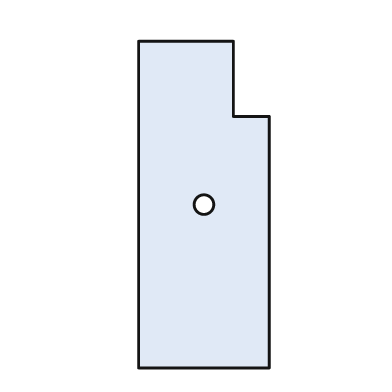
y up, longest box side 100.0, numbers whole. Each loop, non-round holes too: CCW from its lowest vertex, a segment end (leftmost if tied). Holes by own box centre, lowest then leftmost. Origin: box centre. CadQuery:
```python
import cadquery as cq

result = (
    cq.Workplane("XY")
    .moveTo(-20.0, -50.0)
    .lineTo(20.0, -50.0)
    .lineTo(20.0, 27.0)
    .lineTo(9.0, 27.0)
    .lineTo(9.0, 50.0)
    .lineTo(-20.0, 50.0)
    .close()
    .moveTo(0.0, 0.0)
    .circle(3.0)
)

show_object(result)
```